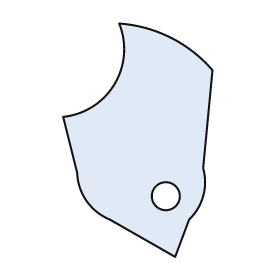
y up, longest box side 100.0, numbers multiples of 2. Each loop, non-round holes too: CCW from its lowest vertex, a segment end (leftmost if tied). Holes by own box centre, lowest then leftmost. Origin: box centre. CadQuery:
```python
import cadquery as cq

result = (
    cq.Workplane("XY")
    .moveTo(16.0, -50.0)
    .lineTo(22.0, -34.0)
    .threePointArc((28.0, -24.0), (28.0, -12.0))
    .lineTo(32.0, 30.0)
    .threePointArc((14.0, 44.0), (-8.0, 50.0))
    .threePointArc((-10.0, 24.0), (-32.0, 10.0))
    .lineTo(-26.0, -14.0)
    .threePointArc((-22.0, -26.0), (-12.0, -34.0))
    .close()
    .moveTo(12.0, -24.0)
    .circle(6.0)
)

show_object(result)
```